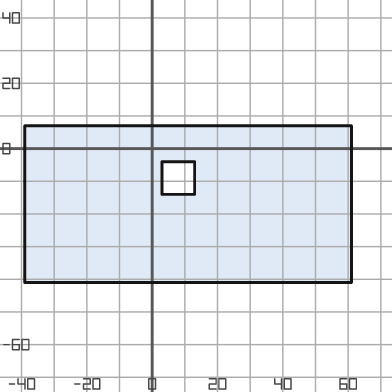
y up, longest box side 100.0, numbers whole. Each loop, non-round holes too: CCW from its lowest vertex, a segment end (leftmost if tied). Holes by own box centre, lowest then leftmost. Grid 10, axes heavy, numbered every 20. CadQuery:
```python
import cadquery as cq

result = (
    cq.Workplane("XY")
    .moveTo(-39.0, -41.0)
    .lineTo(61.0, -41.0)
    .lineTo(61.0, 7.0)
    .lineTo(-39.0, 7.0)
    .close()
    .moveTo(3.0, -14.0)
    .lineTo(13.0, -14.0)
    .lineTo(13.0, -4.0)
    .lineTo(3.0, -4.0)
    .close()
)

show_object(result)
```